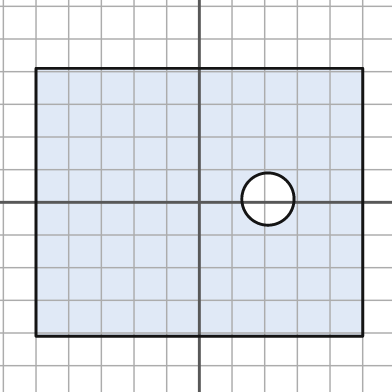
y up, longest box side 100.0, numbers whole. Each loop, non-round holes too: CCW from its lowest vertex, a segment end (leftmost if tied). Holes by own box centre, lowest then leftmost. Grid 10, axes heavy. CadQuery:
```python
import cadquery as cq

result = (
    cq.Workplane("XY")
    .moveTo(-50.0, -41.0)
    .lineTo(50.0, -41.0)
    .lineTo(50.0, 41.0)
    .lineTo(-50.0, 41.0)
    .close()
    .moveTo(21.0, 1.0)
    .circle(8.0)
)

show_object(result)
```